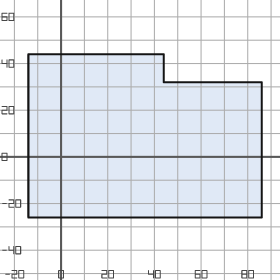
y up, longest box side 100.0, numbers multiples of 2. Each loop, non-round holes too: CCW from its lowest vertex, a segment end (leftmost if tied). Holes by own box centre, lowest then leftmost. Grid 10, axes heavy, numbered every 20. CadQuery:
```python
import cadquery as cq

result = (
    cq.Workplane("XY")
    .moveTo(-14.0, -26.0)
    .lineTo(86.0, -26.0)
    .lineTo(86.0, 32.0)
    .lineTo(44.0, 32.0)
    .lineTo(44.0, 44.0)
    .lineTo(-14.0, 44.0)
    .close()
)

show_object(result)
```